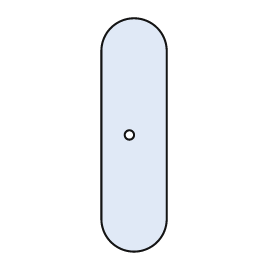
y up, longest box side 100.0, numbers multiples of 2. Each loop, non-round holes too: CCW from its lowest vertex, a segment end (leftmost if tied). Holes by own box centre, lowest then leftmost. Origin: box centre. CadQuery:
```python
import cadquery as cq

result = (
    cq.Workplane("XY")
    .moveTo(-14.0, -36.0)
    .threePointArc((0.0, -50.0), (14.0, -36.0))
    .lineTo(14.0, 36.0)
    .threePointArc((0.0, 50.0), (-14.0, 36.0))
    .close()
    .moveTo(-2.0, 0.0)
    .circle(2.0)
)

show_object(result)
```